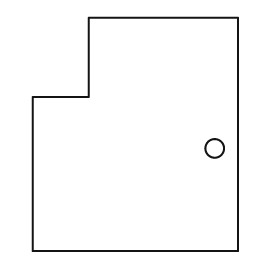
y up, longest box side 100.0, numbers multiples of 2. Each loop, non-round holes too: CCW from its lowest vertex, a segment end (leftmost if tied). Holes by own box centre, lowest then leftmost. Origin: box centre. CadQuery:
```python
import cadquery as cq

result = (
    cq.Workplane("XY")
    .moveTo(-44.0, -50.0)
    .lineTo(44.0, -50.0)
    .lineTo(44.0, 50.0)
    .lineTo(-20.0, 50.0)
    .lineTo(-20.0, 16.0)
    .lineTo(-44.0, 16.0)
    .close()
    .moveTo(34.0, -6.0)
    .circle(4.0)
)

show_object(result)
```